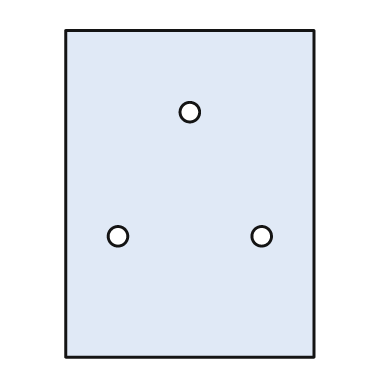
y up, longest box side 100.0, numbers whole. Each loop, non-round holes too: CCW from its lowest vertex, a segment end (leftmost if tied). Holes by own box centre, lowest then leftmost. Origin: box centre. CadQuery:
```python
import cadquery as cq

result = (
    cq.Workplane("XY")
    .moveTo(-38.0, -50.0)
    .lineTo(38.0, -50.0)
    .lineTo(38.0, 50.0)
    .lineTo(-38.0, 50.0)
    .close()
    .moveTo(-22.0, -13.0)
    .circle(3.0)
    .moveTo(22.0, -13.0)
    .circle(3.0)
    .moveTo(0.0, 25.0)
    .circle(3.0)
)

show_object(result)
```